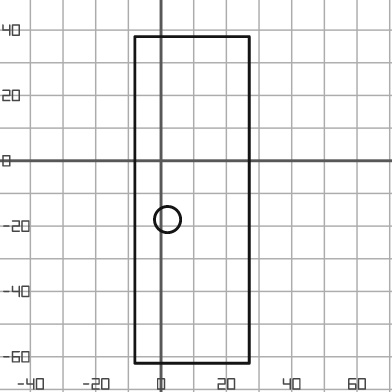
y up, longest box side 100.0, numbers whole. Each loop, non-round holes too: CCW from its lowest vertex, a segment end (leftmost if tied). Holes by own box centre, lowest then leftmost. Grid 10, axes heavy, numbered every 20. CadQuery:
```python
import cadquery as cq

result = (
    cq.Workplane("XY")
    .moveTo(-8.0, -62.0)
    .lineTo(27.0, -62.0)
    .lineTo(27.0, 38.0)
    .lineTo(-8.0, 38.0)
    .close()
    .moveTo(2.0, -18.0)
    .circle(4.0)
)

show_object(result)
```